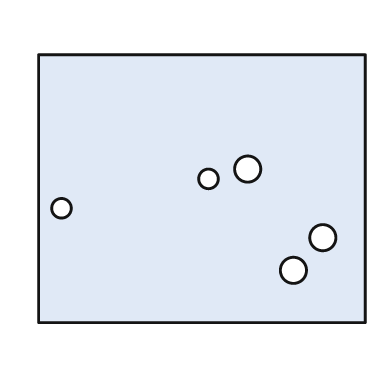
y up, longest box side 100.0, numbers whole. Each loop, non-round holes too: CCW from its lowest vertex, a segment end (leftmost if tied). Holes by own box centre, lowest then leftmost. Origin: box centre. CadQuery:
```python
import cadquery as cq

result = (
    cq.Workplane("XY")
    .moveTo(-50.0, -41.0)
    .lineTo(50.0, -41.0)
    .lineTo(50.0, 41.0)
    .lineTo(-50.0, 41.0)
    .close()
    .moveTo(28.0, -25.0)
    .circle(4.0)
    .moveTo(37.0, -15.0)
    .circle(4.0)
    .moveTo(-43.0, -6.0)
    .circle(3.0)
    .moveTo(2.0, 3.0)
    .circle(3.0)
    .moveTo(14.0, 6.0)
    .circle(4.0)
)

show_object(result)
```